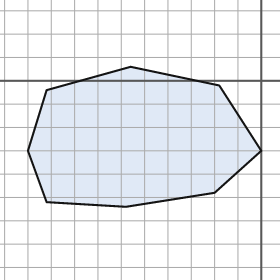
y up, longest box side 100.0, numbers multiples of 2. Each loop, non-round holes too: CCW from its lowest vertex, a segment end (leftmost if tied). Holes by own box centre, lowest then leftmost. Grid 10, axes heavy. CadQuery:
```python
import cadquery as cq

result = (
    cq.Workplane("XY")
    .moveTo(-58.0, -54.0)
    .lineTo(-20.0, -48.0)
    .lineTo(0.0, -30.0)
    .lineTo(-18.0, -2.0)
    .lineTo(-56.0, 6.0)
    .lineTo(-92.0, -4.0)
    .lineTo(-100.0, -30.0)
    .lineTo(-92.0, -52.0)
    .close()
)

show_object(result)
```